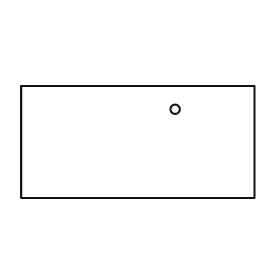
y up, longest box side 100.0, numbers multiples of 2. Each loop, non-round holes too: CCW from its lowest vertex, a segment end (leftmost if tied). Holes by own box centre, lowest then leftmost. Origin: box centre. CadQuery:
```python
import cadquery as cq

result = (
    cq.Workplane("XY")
    .moveTo(-50.0, -24.0)
    .lineTo(50.0, -24.0)
    .lineTo(50.0, 24.0)
    .lineTo(-50.0, 24.0)
    .close()
    .moveTo(16.0, 14.0)
    .circle(2.0)
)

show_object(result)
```